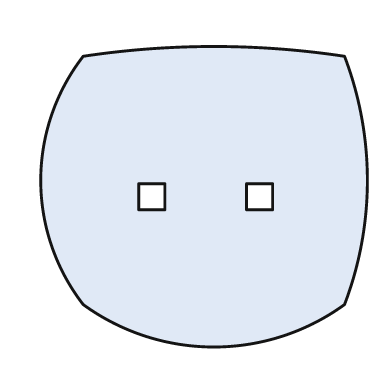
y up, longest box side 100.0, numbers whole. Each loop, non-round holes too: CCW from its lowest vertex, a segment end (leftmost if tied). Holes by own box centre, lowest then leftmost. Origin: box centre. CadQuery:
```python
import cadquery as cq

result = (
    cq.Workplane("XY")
    .moveTo(-37.0, -33.0)
    .threePointArc((3.0, -46.0), (43.0, -33.0))
    .threePointArc((50.0, 5.0), (43.0, 43.0))
    .threePointArc((3.0, 46.0), (-37.0, 43.0))
    .threePointArc((-50.0, 5.0), (-37.0, -33.0))
    .close()
    .moveTo(-20.0, -4.0)
    .lineTo(-12.0, -4.0)
    .lineTo(-12.0, 4.0)
    .lineTo(-20.0, 4.0)
    .close()
    .moveTo(13.0, -4.0)
    .lineTo(21.0, -4.0)
    .lineTo(21.0, 4.0)
    .lineTo(13.0, 4.0)
    .close()
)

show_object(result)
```